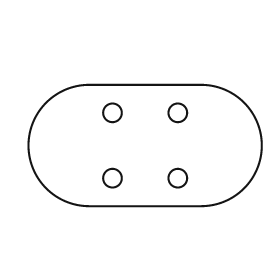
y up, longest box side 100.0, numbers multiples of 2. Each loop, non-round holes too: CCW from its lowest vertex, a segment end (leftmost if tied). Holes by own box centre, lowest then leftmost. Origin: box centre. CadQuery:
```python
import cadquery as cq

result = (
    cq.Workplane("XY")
    .moveTo(-24.0, -26.0)
    .lineTo(24.0, -26.0)
    .threePointArc((50.0, 0.0), (24.0, 26.0))
    .lineTo(-24.0, 26.0)
    .threePointArc((-50.0, 0.0), (-24.0, -26.0))
    .close()
    .moveTo(-14.0, -14.0)
    .circle(4.0)
    .moveTo(14.0, -14.0)
    .circle(4.0)
    .moveTo(-14.0, 14.0)
    .circle(4.0)
    .moveTo(14.0, 14.0)
    .circle(4.0)
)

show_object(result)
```